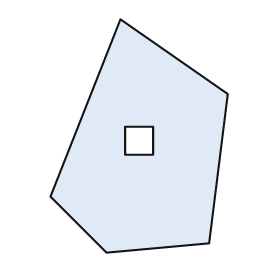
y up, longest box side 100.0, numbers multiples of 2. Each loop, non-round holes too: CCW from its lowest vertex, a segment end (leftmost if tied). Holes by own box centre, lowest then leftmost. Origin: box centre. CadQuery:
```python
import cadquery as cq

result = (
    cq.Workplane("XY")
    .moveTo(-14.0, -50.0)
    .lineTo(30.0, -46.0)
    .lineTo(38.0, 18.0)
    .lineTo(-8.0, 50.0)
    .lineTo(-38.0, -26.0)
    .close()
    .moveTo(-6.0, -8.0)
    .lineTo(6.0, -8.0)
    .lineTo(6.0, 4.0)
    .lineTo(-6.0, 4.0)
    .close()
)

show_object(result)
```